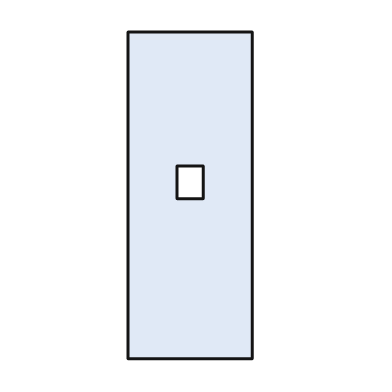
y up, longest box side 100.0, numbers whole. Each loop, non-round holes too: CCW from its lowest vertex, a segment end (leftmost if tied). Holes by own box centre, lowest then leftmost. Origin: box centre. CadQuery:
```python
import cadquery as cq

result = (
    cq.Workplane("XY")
    .moveTo(-19.0, -50.0)
    .lineTo(19.0, -50.0)
    .lineTo(19.0, 50.0)
    .lineTo(-19.0, 50.0)
    .close()
    .moveTo(-4.0, -1.0)
    .lineTo(4.0, -1.0)
    .lineTo(4.0, 9.0)
    .lineTo(-4.0, 9.0)
    .close()
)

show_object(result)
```